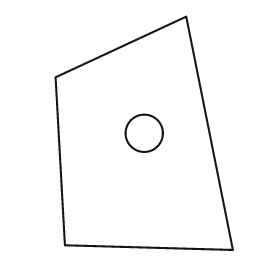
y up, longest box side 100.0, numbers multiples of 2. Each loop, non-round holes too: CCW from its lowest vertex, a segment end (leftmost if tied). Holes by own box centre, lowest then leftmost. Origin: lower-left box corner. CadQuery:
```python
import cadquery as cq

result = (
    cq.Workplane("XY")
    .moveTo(76.0, 0.0)
    .lineTo(56.0, 100.0)
    .lineTo(0.0, 74.0)
    .lineTo(4.0, 2.0)
    .close()
    .moveTo(38.0, 50.0)
    .circle(8.0)
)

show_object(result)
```